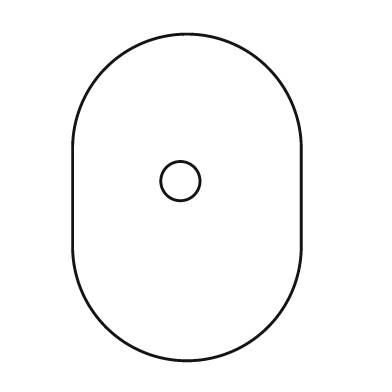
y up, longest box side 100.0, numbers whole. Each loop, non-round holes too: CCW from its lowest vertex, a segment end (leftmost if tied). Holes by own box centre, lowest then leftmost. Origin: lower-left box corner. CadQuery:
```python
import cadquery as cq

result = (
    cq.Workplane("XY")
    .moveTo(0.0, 35.0)
    .threePointArc((35.0, 0.0), (70.0, 35.0))
    .lineTo(70.0, 65.0)
    .threePointArc((35.0, 100.0), (0.0, 65.0))
    .close()
    .moveTo(33.0, 55.0)
    .circle(6.0)
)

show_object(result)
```